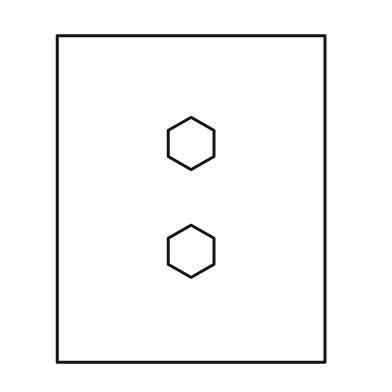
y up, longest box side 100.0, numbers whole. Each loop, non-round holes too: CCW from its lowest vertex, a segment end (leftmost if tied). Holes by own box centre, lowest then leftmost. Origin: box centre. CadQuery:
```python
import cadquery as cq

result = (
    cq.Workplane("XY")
    .moveTo(-41.0, -50.0)
    .lineTo(41.0, -50.0)
    .lineTo(41.0, 50.0)
    .lineTo(-41.0, 50.0)
    .close()
    .moveTo(0.0, -24.0)
    .lineTo(7.0, -20.0)
    .lineTo(7.0, -12.0)
    .lineTo(0.0, -8.0)
    .lineTo(-7.0, -12.0)
    .lineTo(-7.0, -20.0)
    .close()
    .moveTo(0.0, 9.0)
    .lineTo(7.0, 13.0)
    .lineTo(7.0, 21.0)
    .lineTo(0.0, 25.0)
    .lineTo(-7.0, 21.0)
    .lineTo(-7.0, 13.0)
    .close()
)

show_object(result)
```